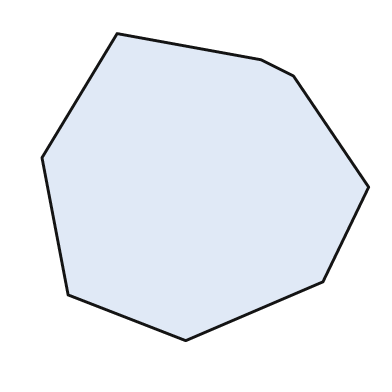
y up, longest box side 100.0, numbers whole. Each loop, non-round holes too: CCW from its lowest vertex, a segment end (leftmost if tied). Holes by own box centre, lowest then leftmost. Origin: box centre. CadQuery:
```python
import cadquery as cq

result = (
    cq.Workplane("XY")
    .moveTo(-6.0, -47.0)
    .lineTo(36.0, -29.0)
    .lineTo(50.0, 0.0)
    .lineTo(27.0, 34.0)
    .lineTo(17.0, 39.0)
    .lineTo(-27.0, 47.0)
    .lineTo(-50.0, 9.0)
    .lineTo(-42.0, -33.0)
    .close()
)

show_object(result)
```